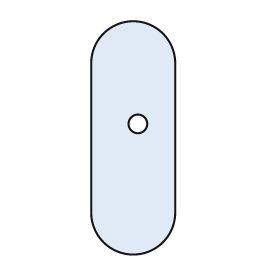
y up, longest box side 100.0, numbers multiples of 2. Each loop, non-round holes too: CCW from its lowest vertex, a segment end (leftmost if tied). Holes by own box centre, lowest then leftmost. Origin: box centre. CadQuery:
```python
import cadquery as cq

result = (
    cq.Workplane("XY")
    .moveTo(-18.0, -32.0)
    .threePointArc((0.0, -50.0), (18.0, -32.0))
    .lineTo(18.0, 32.0)
    .threePointArc((0.0, 50.0), (-18.0, 32.0))
    .close()
    .moveTo(2.0, 6.0)
    .circle(4.0)
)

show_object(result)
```